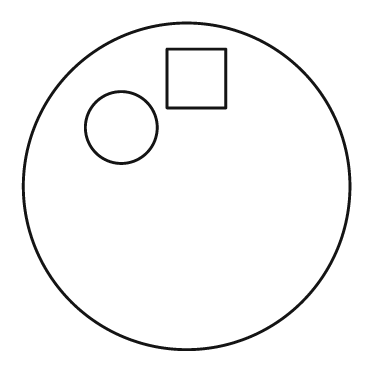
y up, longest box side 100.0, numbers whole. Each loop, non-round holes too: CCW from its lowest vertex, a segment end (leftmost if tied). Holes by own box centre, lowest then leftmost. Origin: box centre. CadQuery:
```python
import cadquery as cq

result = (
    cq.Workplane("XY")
    .moveTo(0.0, 0.0)
    .circle(50.0)
    .moveTo(-20.0, 18.0)
    .circle(11.0)
    .moveTo(-6.0, 24.0)
    .lineTo(12.0, 24.0)
    .lineTo(12.0, 42.0)
    .lineTo(-6.0, 42.0)
    .close()
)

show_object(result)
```